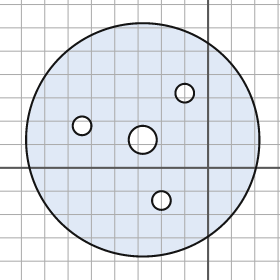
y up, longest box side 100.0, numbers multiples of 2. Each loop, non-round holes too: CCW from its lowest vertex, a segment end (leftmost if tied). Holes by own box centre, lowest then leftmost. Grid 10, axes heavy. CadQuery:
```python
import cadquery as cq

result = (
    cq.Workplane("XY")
    .moveTo(-28.0, 12.0)
    .circle(50.0)
    .moveTo(-20.0, -14.0)
    .circle(4.0)
    .moveTo(-28.0, 12.0)
    .circle(6.0)
    .moveTo(-54.0, 18.0)
    .circle(4.0)
    .moveTo(-10.0, 32.0)
    .circle(4.0)
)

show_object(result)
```